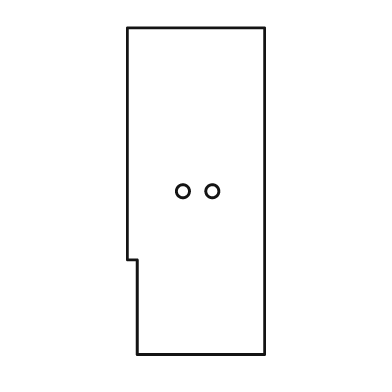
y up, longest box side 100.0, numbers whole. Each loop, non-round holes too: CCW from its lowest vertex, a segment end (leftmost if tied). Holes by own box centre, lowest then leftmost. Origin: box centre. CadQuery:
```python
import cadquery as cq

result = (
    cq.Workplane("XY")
    .moveTo(-18.0, -50.0)
    .lineTo(21.0, -50.0)
    .lineTo(21.0, 50.0)
    .lineTo(-21.0, 50.0)
    .lineTo(-21.0, -21.0)
    .lineTo(-18.0, -21.0)
    .close()
    .moveTo(-4.0, 0.0)
    .circle(2.0)
    .moveTo(5.0, 0.0)
    .circle(2.0)
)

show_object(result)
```